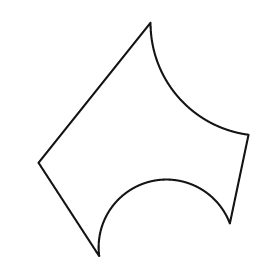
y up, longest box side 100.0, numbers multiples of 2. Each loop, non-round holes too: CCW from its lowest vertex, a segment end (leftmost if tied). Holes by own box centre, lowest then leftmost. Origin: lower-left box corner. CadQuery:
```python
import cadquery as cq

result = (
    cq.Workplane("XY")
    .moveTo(26.0, 0.0)
    .threePointArc((48.0, 32.0), (82.0, 14.0))
    .lineTo(90.0, 52.0)
    .threePointArc((60.0, 68.0), (48.0, 100.0))
    .lineTo(0.0, 40.0)
    .close()
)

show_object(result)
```